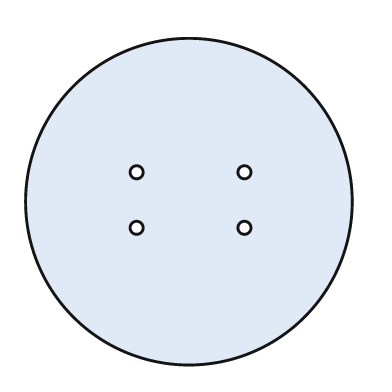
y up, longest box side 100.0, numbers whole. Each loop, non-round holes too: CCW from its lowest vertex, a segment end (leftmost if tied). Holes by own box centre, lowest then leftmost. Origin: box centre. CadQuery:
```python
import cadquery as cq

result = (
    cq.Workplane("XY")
    .moveTo(0.0, 0.0)
    .circle(50.0)
    .moveTo(-16.0, -8.0)
    .circle(2.0)
    .moveTo(17.0, -8.0)
    .circle(2.0)
    .moveTo(-16.0, 9.0)
    .circle(2.0)
    .moveTo(17.0, 9.0)
    .circle(2.0)
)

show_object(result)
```